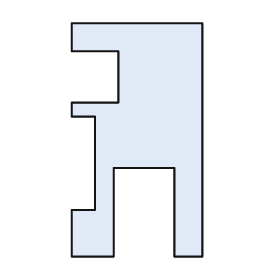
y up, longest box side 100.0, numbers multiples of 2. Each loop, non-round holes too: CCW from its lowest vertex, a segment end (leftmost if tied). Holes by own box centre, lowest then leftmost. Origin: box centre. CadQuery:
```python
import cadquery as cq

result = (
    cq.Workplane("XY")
    .moveTo(-28.0, -50.0)
    .lineTo(-10.0, -50.0)
    .lineTo(-10.0, -12.0)
    .lineTo(16.0, -12.0)
    .lineTo(16.0, -50.0)
    .lineTo(28.0, -50.0)
    .lineTo(28.0, 50.0)
    .lineTo(-28.0, 50.0)
    .lineTo(-28.0, 38.0)
    .lineTo(-8.0, 38.0)
    .lineTo(-8.0, 16.0)
    .lineTo(-28.0, 16.0)
    .lineTo(-28.0, 10.0)
    .lineTo(-18.0, 10.0)
    .lineTo(-18.0, -30.0)
    .lineTo(-28.0, -30.0)
    .close()
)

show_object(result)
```